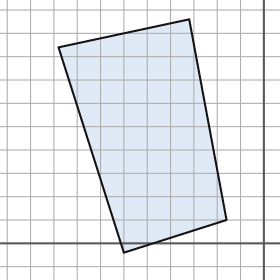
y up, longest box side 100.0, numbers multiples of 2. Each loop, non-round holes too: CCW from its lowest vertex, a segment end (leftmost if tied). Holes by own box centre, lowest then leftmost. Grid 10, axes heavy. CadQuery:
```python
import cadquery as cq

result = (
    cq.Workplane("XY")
    .moveTo(-60.0, -4.0)
    .lineTo(-16.0, 10.0)
    .lineTo(-32.0, 96.0)
    .lineTo(-88.0, 84.0)
    .close()
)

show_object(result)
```